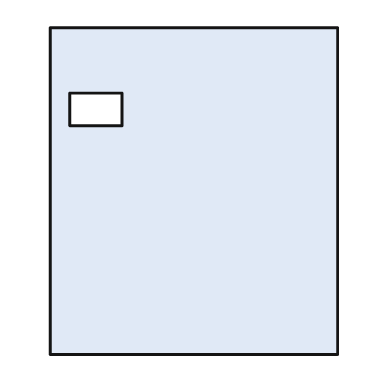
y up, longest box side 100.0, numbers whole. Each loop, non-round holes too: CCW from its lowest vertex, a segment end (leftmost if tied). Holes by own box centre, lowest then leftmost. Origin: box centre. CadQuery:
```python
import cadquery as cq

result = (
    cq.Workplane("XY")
    .moveTo(-44.0, -50.0)
    .lineTo(44.0, -50.0)
    .lineTo(44.0, 50.0)
    .lineTo(-44.0, 50.0)
    .close()
    .moveTo(-38.0, 20.0)
    .lineTo(-22.0, 20.0)
    .lineTo(-22.0, 30.0)
    .lineTo(-38.0, 30.0)
    .close()
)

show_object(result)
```